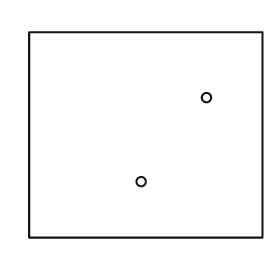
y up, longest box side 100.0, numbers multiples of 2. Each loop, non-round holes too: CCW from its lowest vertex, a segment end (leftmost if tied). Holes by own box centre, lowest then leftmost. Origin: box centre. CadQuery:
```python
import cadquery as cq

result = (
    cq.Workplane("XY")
    .moveTo(-50.0, -44.0)
    .lineTo(50.0, -44.0)
    .lineTo(50.0, 44.0)
    .lineTo(-50.0, 44.0)
    .close()
    .moveTo(-2.0, -20.0)
    .circle(2.0)
    .moveTo(26.0, 16.0)
    .circle(2.0)
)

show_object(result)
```